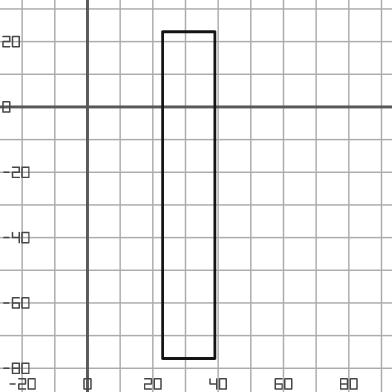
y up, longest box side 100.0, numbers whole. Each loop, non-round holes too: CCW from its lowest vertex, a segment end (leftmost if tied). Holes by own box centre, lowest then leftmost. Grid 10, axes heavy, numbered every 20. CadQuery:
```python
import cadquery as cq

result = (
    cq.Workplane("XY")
    .moveTo(23.0, -77.0)
    .lineTo(39.0, -77.0)
    .lineTo(39.0, 23.0)
    .lineTo(23.0, 23.0)
    .close()
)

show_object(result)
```